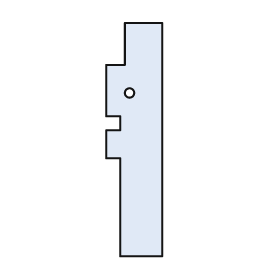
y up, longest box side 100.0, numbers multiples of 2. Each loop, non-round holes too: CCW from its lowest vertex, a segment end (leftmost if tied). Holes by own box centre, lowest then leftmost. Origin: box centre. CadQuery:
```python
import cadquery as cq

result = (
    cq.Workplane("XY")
    .moveTo(-6.0, -50.0)
    .lineTo(12.0, -50.0)
    .lineTo(12.0, 50.0)
    .lineTo(-4.0, 50.0)
    .lineTo(-4.0, 32.0)
    .lineTo(-12.0, 32.0)
    .lineTo(-12.0, 10.0)
    .lineTo(-6.0, 10.0)
    .lineTo(-6.0, 4.0)
    .lineTo(-12.0, 4.0)
    .lineTo(-12.0, -8.0)
    .lineTo(-6.0, -8.0)
    .close()
    .moveTo(-2.0, 20.0)
    .circle(2.0)
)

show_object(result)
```